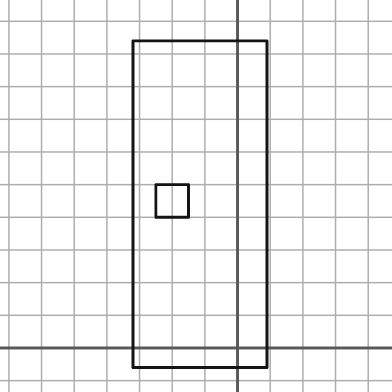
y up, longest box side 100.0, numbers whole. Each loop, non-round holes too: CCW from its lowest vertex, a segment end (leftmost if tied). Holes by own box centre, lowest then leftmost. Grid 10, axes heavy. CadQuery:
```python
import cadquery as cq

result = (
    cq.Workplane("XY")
    .moveTo(-32.0, -6.0)
    .lineTo(9.0, -6.0)
    .lineTo(9.0, 94.0)
    .lineTo(-32.0, 94.0)
    .close()
    .moveTo(-25.0, 40.0)
    .lineTo(-15.0, 40.0)
    .lineTo(-15.0, 50.0)
    .lineTo(-25.0, 50.0)
    .close()
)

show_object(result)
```